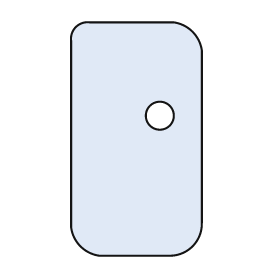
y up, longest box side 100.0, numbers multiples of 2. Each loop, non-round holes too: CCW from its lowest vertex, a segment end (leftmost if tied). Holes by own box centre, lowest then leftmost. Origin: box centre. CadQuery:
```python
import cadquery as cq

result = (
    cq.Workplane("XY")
    .moveTo(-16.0, -50.0)
    .lineTo(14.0, -50.0)
    .threePointArc((24.0, -46.0), (28.0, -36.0))
    .lineTo(28.0, 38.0)
    .threePointArc((24.0, 46.0), (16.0, 50.0))
    .lineTo(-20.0, 50.0)
    .threePointArc((-26.0, 48.0), (-28.0, 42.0))
    .lineTo(-28.0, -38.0)
    .threePointArc((-24.0, -46.0), (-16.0, -50.0))
    .close()
    .moveTo(10.0, 10.0)
    .circle(6.0)
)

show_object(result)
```